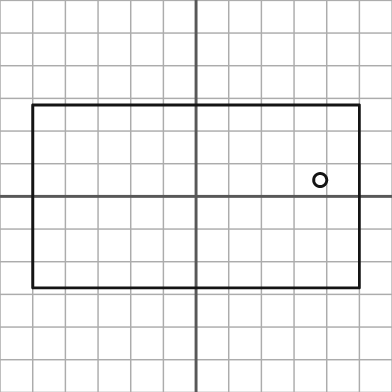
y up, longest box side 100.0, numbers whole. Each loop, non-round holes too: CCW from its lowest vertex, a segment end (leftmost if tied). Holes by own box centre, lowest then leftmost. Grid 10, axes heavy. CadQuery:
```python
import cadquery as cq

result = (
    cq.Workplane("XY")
    .moveTo(-50.0, -28.0)
    .lineTo(50.0, -28.0)
    .lineTo(50.0, 28.0)
    .lineTo(-50.0, 28.0)
    .close()
    .moveTo(38.0, 5.0)
    .circle(2.0)
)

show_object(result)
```